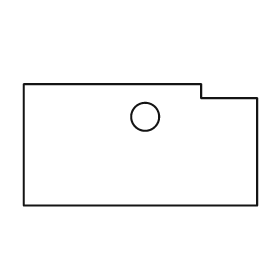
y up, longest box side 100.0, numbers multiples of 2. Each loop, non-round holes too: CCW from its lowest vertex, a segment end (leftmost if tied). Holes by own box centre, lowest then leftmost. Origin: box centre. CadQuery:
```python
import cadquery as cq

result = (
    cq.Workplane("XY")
    .moveTo(-50.0, -26.0)
    .lineTo(50.0, -26.0)
    .lineTo(50.0, 20.0)
    .lineTo(26.0, 20.0)
    .lineTo(26.0, 26.0)
    .lineTo(-50.0, 26.0)
    .close()
    .moveTo(2.0, 12.0)
    .circle(6.0)
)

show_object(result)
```